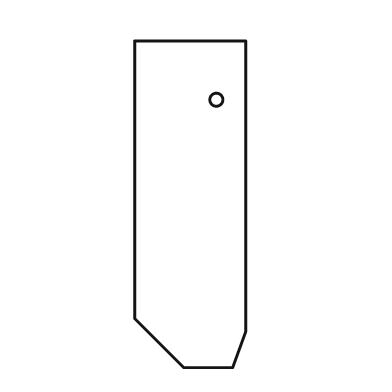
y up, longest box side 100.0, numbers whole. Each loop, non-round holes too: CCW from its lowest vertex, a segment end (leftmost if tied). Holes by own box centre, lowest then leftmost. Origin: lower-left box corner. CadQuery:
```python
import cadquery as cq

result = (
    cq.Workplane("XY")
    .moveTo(15.0, 0.0)
    .lineTo(30.0, 0.0)
    .lineTo(34.0, 11.0)
    .lineTo(34.0, 100.0)
    .lineTo(0.0, 100.0)
    .lineTo(0.0, 15.0)
    .close()
    .moveTo(25.0, 82.0)
    .circle(2.0)
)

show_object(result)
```